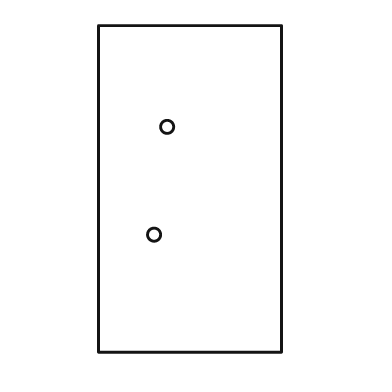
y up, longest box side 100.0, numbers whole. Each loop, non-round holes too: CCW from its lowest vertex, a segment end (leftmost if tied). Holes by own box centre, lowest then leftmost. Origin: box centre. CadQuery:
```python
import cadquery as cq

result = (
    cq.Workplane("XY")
    .moveTo(-28.0, -50.0)
    .lineTo(28.0, -50.0)
    .lineTo(28.0, 50.0)
    .lineTo(-28.0, 50.0)
    .close()
    .moveTo(-11.0, -14.0)
    .circle(2.0)
    .moveTo(-7.0, 19.0)
    .circle(2.0)
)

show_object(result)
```